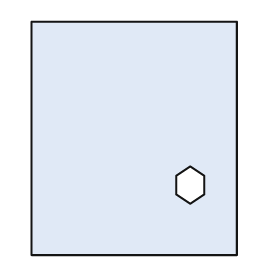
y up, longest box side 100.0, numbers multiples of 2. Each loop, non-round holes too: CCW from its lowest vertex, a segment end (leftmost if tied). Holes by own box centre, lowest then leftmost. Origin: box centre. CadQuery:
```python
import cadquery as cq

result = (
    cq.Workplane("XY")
    .moveTo(-44.0, -50.0)
    .lineTo(44.0, -50.0)
    .lineTo(44.0, 50.0)
    .lineTo(-44.0, 50.0)
    .close()
    .moveTo(24.0, -28.0)
    .lineTo(30.0, -24.0)
    .lineTo(30.0, -16.0)
    .lineTo(24.0, -12.0)
    .lineTo(18.0, -16.0)
    .lineTo(18.0, -24.0)
    .close()
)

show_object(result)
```